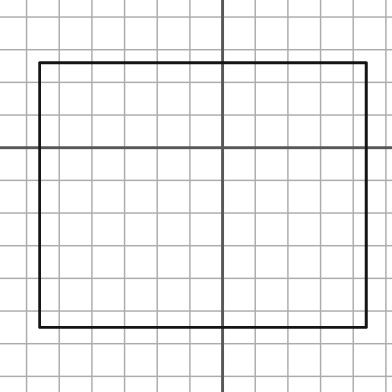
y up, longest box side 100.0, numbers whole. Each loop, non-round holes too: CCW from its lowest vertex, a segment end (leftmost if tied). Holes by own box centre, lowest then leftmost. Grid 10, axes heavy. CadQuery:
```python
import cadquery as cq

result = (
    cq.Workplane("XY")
    .moveTo(-56.0, -55.0)
    .lineTo(44.0, -55.0)
    .lineTo(44.0, 26.0)
    .lineTo(-56.0, 26.0)
    .close()
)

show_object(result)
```